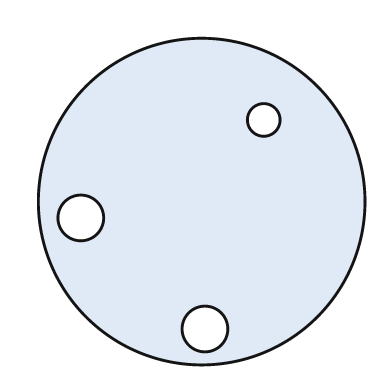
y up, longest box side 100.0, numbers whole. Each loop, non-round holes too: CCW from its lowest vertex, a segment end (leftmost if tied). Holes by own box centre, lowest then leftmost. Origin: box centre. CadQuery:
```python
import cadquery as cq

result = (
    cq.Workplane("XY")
    .moveTo(0.0, 0.0)
    .circle(50.0)
    .moveTo(1.0, -39.0)
    .circle(7.0)
    .moveTo(-37.0, -5.0)
    .circle(7.0)
    .moveTo(19.0, 25.0)
    .circle(5.0)
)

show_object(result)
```